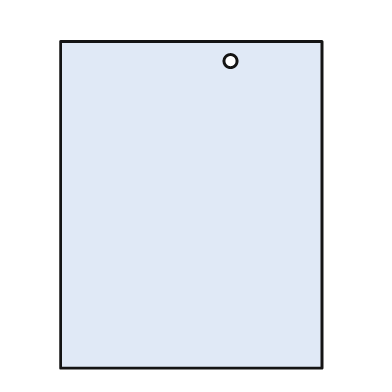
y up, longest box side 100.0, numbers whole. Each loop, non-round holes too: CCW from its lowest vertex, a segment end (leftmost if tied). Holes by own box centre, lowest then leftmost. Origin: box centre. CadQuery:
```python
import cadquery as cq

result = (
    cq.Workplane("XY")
    .moveTo(-40.0, -50.0)
    .lineTo(40.0, -50.0)
    .lineTo(40.0, 50.0)
    .lineTo(-40.0, 50.0)
    .close()
    .moveTo(12.0, 44.0)
    .circle(2.0)
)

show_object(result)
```